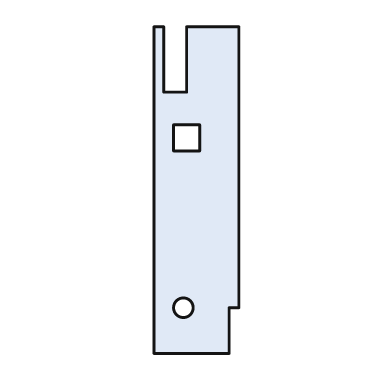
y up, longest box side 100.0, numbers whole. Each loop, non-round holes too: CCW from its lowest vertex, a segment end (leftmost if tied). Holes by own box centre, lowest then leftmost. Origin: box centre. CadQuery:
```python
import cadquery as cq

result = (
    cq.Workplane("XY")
    .moveTo(-13.0, -50.0)
    .lineTo(10.0, -50.0)
    .lineTo(10.0, -36.0)
    .lineTo(13.0, -36.0)
    .lineTo(13.0, 50.0)
    .lineTo(-3.0, 50.0)
    .lineTo(-3.0, 30.0)
    .lineTo(-10.0, 30.0)
    .lineTo(-10.0, 50.0)
    .lineTo(-13.0, 50.0)
    .close()
    .moveTo(-4.0, -36.0)
    .circle(3.0)
    .moveTo(-7.0, 12.0)
    .lineTo(1.0, 12.0)
    .lineTo(1.0, 20.0)
    .lineTo(-7.0, 20.0)
    .close()
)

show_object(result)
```